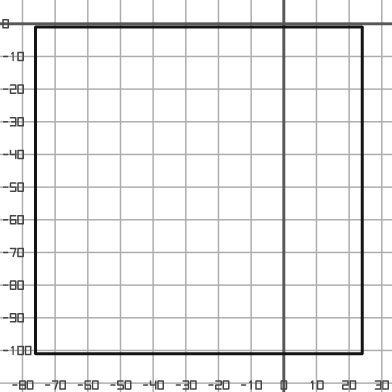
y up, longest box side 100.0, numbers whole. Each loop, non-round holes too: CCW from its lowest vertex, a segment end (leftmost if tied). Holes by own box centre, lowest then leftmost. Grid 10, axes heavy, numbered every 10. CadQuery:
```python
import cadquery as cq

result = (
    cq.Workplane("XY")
    .moveTo(-76.0, -101.0)
    .lineTo(24.0, -101.0)
    .lineTo(24.0, -1.0)
    .lineTo(-76.0, -1.0)
    .close()
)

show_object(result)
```